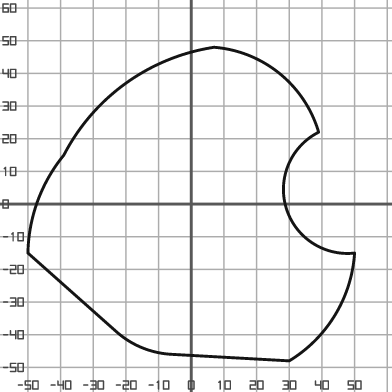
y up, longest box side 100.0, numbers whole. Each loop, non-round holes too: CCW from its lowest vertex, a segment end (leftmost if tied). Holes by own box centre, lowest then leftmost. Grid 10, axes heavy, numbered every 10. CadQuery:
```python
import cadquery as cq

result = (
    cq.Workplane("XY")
    .moveTo(30.0, -48.0)
    .threePointArc((44.0, -34.0), (50.0, -15.0))
    .threePointArc((29.0, -1.0), (39.0, 22.0))
    .threePointArc((27.0, 40.0), (7.0, 48.0))
    .threePointArc((-20.0, 37.0), (-39.0, 15.0))
    .threePointArc((-47.0, 1.0), (-50.0, -15.0))
    .lineTo(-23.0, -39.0)
    .threePointArc((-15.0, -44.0), (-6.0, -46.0))
    .close()
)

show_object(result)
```